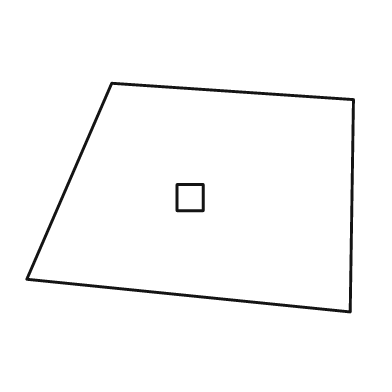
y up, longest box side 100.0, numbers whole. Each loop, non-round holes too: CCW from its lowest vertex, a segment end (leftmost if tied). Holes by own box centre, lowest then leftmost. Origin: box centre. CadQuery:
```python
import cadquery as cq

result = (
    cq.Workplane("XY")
    .moveTo(49.0, -35.0)
    .lineTo(50.0, 30.0)
    .lineTo(-24.0, 35.0)
    .lineTo(-50.0, -25.0)
    .close()
    .moveTo(-4.0, -4.0)
    .lineTo(4.0, -4.0)
    .lineTo(4.0, 4.0)
    .lineTo(-4.0, 4.0)
    .close()
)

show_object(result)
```